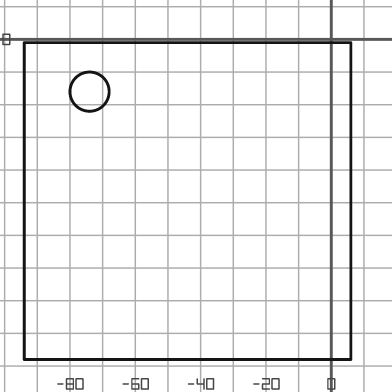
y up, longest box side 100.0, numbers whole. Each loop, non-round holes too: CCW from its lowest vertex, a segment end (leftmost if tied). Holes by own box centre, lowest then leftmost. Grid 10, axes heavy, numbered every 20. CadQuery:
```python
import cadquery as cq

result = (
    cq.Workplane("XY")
    .moveTo(-94.0, -98.0)
    .lineTo(6.0, -98.0)
    .lineTo(6.0, -1.0)
    .lineTo(-94.0, -1.0)
    .close()
    .moveTo(-74.0, -16.0)
    .circle(6.0)
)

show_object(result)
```